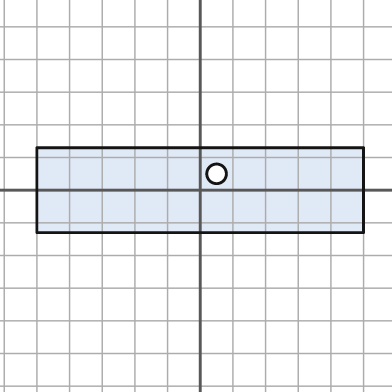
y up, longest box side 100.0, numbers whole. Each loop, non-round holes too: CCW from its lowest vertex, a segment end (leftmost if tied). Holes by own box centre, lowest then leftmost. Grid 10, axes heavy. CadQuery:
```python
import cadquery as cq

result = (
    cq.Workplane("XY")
    .moveTo(-50.0, -13.0)
    .lineTo(50.0, -13.0)
    .lineTo(50.0, 13.0)
    .lineTo(-50.0, 13.0)
    .close()
    .moveTo(5.0, 5.0)
    .circle(3.0)
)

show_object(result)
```